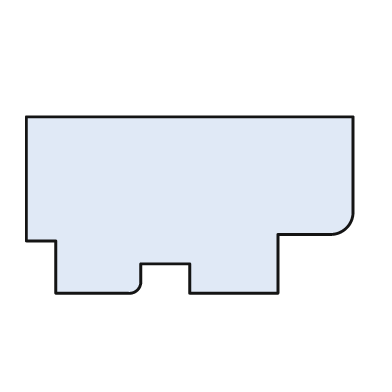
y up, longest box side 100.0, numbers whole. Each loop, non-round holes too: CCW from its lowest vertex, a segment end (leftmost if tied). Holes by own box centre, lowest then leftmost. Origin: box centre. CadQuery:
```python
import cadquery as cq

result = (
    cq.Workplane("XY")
    .moveTo(-41.0, -27.0)
    .lineTo(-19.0, -27.0)
    .threePointArc((-16.0, -26.0), (-15.0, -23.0))
    .lineTo(-15.0, -18.0)
    .lineTo(0.0, -18.0)
    .lineTo(0.0, -27.0)
    .lineTo(27.0, -27.0)
    .lineTo(27.0, -9.0)
    .lineTo(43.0, -9.0)
    .threePointArc((48.0, -7.0), (50.0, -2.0))
    .lineTo(50.0, 27.0)
    .lineTo(-50.0, 27.0)
    .lineTo(-50.0, -11.0)
    .lineTo(-41.0, -11.0)
    .close()
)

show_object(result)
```